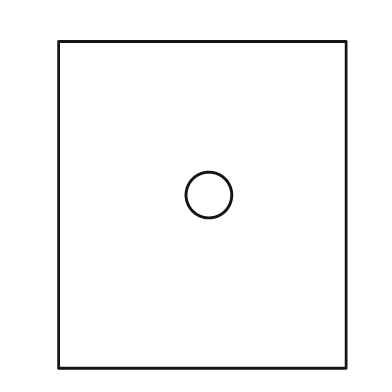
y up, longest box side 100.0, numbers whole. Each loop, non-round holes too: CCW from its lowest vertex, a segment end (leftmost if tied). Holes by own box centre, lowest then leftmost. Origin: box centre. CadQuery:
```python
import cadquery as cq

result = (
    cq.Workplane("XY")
    .moveTo(-44.0, -50.0)
    .lineTo(44.0, -50.0)
    .lineTo(44.0, 50.0)
    .lineTo(-44.0, 50.0)
    .close()
    .moveTo(2.0, 3.0)
    .circle(7.0)
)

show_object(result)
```